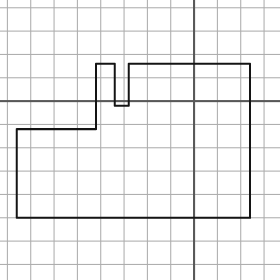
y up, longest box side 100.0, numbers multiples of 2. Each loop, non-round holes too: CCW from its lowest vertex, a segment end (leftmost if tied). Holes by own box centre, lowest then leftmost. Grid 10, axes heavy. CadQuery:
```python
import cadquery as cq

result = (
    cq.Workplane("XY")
    .moveTo(-76.0, -50.0)
    .lineTo(24.0, -50.0)
    .lineTo(24.0, 16.0)
    .lineTo(-28.0, 16.0)
    .lineTo(-28.0, -2.0)
    .lineTo(-34.0, -2.0)
    .lineTo(-34.0, 16.0)
    .lineTo(-42.0, 16.0)
    .lineTo(-42.0, -12.0)
    .lineTo(-76.0, -12.0)
    .close()
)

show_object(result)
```